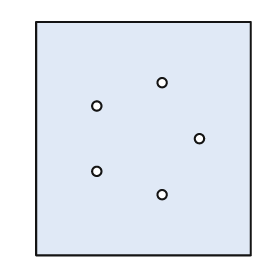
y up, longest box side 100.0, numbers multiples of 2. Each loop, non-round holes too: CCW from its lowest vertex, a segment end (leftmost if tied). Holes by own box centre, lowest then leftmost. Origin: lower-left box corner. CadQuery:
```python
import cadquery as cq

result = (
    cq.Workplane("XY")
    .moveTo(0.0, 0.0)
    .lineTo(92.0, 0.0)
    .lineTo(92.0, 100.0)
    .lineTo(0.0, 100.0)
    .close()
    .moveTo(54.0, 26.0)
    .circle(2.0)
    .moveTo(26.0, 36.0)
    .circle(2.0)
    .moveTo(70.0, 50.0)
    .circle(2.0)
    .moveTo(26.0, 64.0)
    .circle(2.0)
    .moveTo(54.0, 74.0)
    .circle(2.0)
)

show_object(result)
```